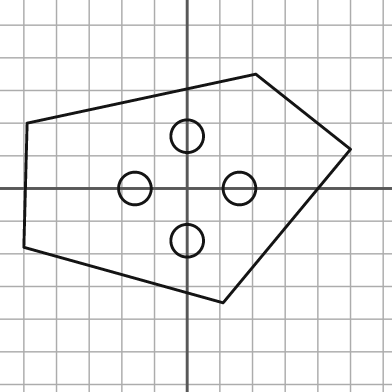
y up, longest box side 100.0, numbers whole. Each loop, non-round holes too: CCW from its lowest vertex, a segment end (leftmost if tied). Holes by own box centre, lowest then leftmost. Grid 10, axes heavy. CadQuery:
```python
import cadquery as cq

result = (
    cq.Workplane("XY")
    .moveTo(11.0, -35.0)
    .lineTo(50.0, 12.0)
    .lineTo(21.0, 35.0)
    .lineTo(-49.0, 20.0)
    .lineTo(-50.0, -18.0)
    .close()
    .moveTo(0.0, -16.0)
    .circle(5.0)
    .moveTo(-16.0, 0.0)
    .circle(5.0)
    .moveTo(16.0, 0.0)
    .circle(5.0)
    .moveTo(0.0, 16.0)
    .circle(5.0)
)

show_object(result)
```